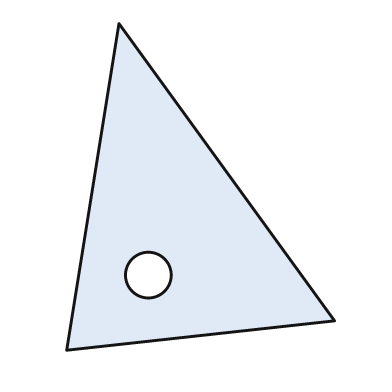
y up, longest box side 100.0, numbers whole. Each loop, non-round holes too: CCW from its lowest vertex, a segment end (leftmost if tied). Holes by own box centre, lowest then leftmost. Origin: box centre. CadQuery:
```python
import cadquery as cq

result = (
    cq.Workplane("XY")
    .moveTo(-41.0, -50.0)
    .lineTo(41.0, -41.0)
    .lineTo(-25.0, 50.0)
    .close()
    .moveTo(-16.0, -27.0)
    .circle(7.0)
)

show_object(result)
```